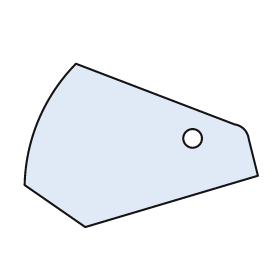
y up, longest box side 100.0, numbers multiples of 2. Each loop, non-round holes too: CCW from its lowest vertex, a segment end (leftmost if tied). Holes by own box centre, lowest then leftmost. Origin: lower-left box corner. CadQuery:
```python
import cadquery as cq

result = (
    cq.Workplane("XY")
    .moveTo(26.0, 0.0)
    .lineTo(100.0, 22.0)
    .lineTo(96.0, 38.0)
    .threePointArc((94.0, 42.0), (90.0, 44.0))
    .lineTo(22.0, 70.0)
    .threePointArc((6.0, 46.0), (0.0, 18.0))
    .close()
    .moveTo(72.0, 38.0)
    .circle(4.0)
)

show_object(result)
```